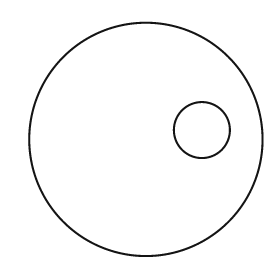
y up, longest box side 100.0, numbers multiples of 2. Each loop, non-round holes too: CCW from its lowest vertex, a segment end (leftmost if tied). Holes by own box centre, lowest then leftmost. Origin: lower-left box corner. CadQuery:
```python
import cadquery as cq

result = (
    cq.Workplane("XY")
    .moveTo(50.0, 50.0)
    .circle(50.0)
    .moveTo(74.0, 54.0)
    .circle(12.0)
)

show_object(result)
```